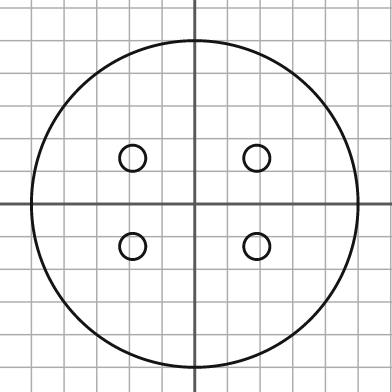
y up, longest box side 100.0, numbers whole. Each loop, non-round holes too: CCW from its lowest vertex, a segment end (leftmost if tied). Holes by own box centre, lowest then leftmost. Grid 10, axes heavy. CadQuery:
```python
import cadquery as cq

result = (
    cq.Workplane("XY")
    .moveTo(0.0, 0.0)
    .circle(50.0)
    .moveTo(-19.0, -13.0)
    .circle(4.0)
    .moveTo(19.0, -13.0)
    .circle(4.0)
    .moveTo(-19.0, 14.0)
    .circle(4.0)
    .moveTo(19.0, 14.0)
    .circle(4.0)
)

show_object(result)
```